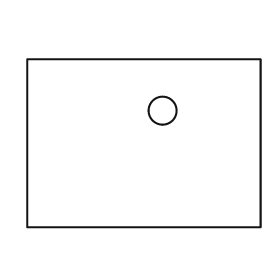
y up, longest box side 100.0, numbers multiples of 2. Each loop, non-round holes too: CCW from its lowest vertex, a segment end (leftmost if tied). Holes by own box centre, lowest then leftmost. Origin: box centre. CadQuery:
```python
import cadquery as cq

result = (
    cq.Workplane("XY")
    .moveTo(-50.0, -36.0)
    .lineTo(50.0, -36.0)
    .lineTo(50.0, 36.0)
    .lineTo(-50.0, 36.0)
    .close()
    .moveTo(8.0, 14.0)
    .circle(6.0)
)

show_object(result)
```